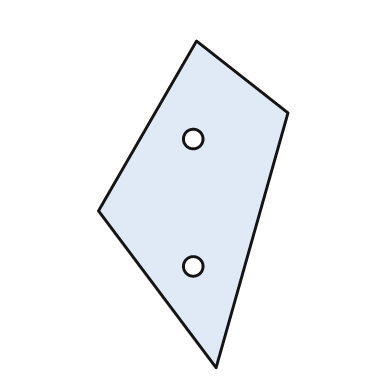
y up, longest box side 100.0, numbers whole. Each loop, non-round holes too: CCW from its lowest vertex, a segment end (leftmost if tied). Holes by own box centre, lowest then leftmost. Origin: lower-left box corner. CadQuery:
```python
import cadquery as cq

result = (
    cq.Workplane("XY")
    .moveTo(36.0, 0.0)
    .lineTo(58.0, 78.0)
    .lineTo(30.0, 100.0)
    .lineTo(0.0, 48.0)
    .close()
    .moveTo(29.0, 31.0)
    .circle(3.0)
    .moveTo(29.0, 70.0)
    .circle(3.0)
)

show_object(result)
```